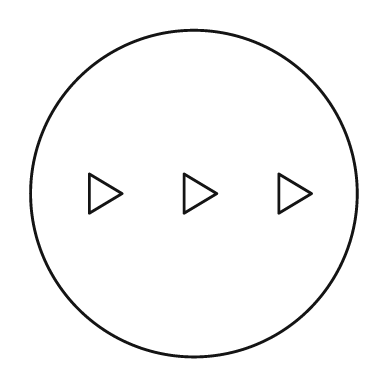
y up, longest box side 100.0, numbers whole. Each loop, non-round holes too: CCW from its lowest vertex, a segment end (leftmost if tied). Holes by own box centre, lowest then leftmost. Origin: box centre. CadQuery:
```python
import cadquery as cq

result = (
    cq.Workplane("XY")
    .moveTo(0.0, 0.0)
    .circle(50.0)
    .moveTo(-32.0, -6.0)
    .lineTo(-22.0, 0.0)
    .lineTo(-32.0, 6.0)
    .close()
    .moveTo(-3.0, -6.0)
    .lineTo(7.0, 0.0)
    .lineTo(-3.0, 6.0)
    .close()
    .moveTo(26.0, -6.0)
    .lineTo(36.0, 0.0)
    .lineTo(26.0, 6.0)
    .close()
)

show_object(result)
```